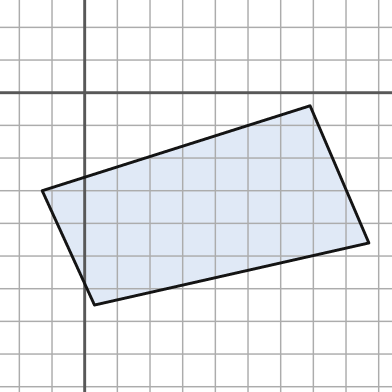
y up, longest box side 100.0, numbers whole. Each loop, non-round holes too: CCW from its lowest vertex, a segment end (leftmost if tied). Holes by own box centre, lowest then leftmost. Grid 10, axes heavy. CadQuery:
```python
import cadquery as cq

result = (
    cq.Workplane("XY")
    .moveTo(3.0, -65.0)
    .lineTo(87.0, -46.0)
    .lineTo(69.0, -4.0)
    .lineTo(-13.0, -30.0)
    .close()
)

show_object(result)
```